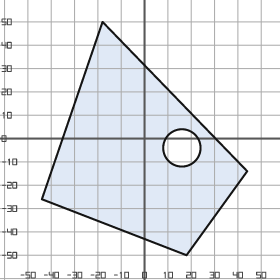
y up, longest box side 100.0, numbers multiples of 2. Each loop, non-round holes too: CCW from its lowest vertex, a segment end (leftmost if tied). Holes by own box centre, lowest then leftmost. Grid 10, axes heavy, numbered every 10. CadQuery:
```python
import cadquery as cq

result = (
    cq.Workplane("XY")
    .moveTo(18.0, -50.0)
    .lineTo(44.0, -14.0)
    .lineTo(-18.0, 50.0)
    .lineTo(-44.0, -26.0)
    .close()
    .moveTo(16.0, -4.0)
    .circle(8.0)
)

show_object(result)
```